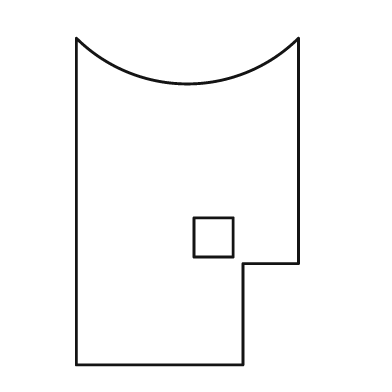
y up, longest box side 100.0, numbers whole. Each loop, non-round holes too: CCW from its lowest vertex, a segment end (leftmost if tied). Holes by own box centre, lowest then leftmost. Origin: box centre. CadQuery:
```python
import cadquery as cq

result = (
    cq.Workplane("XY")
    .moveTo(-34.0, -50.0)
    .lineTo(17.0, -50.0)
    .lineTo(17.0, -19.0)
    .lineTo(34.0, -19.0)
    .lineTo(34.0, 50.0)
    .threePointArc((0.0, 36.0), (-34.0, 50.0))
    .close()
    .moveTo(2.0, -17.0)
    .lineTo(14.0, -17.0)
    .lineTo(14.0, -5.0)
    .lineTo(2.0, -5.0)
    .close()
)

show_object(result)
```